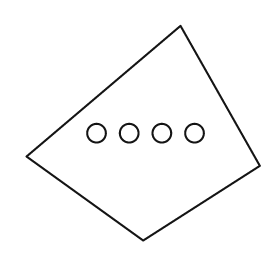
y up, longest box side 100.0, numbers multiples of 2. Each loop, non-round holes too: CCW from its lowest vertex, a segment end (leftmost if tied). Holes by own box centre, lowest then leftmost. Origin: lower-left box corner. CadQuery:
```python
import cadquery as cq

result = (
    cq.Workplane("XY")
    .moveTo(50.0, 0.0)
    .lineTo(100.0, 32.0)
    .lineTo(66.0, 92.0)
    .lineTo(0.0, 36.0)
    .close()
    .moveTo(30.0, 46.0)
    .circle(4.0)
    .moveTo(44.0, 46.0)
    .circle(4.0)
    .moveTo(58.0, 46.0)
    .circle(4.0)
    .moveTo(72.0, 46.0)
    .circle(4.0)
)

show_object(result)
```